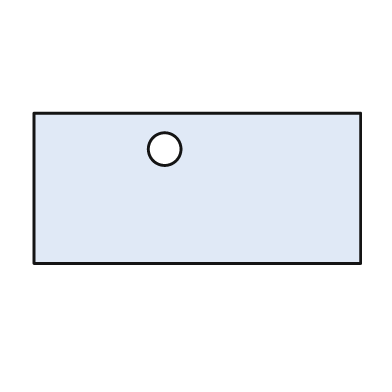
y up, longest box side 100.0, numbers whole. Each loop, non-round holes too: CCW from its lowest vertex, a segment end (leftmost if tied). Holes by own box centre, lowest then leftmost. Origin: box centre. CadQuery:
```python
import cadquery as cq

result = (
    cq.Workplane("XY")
    .moveTo(-50.0, -23.0)
    .lineTo(50.0, -23.0)
    .lineTo(50.0, 23.0)
    .lineTo(-50.0, 23.0)
    .close()
    .moveTo(-10.0, 12.0)
    .circle(5.0)
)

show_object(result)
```